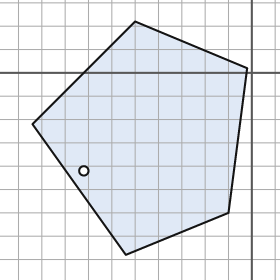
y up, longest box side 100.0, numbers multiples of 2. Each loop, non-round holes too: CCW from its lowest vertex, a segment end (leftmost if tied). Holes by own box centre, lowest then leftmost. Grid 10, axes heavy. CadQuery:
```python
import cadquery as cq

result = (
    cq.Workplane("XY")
    .moveTo(-54.0, -78.0)
    .lineTo(-10.0, -60.0)
    .lineTo(-2.0, 2.0)
    .lineTo(-50.0, 22.0)
    .lineTo(-94.0, -22.0)
    .close()
    .moveTo(-72.0, -42.0)
    .circle(2.0)
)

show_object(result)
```